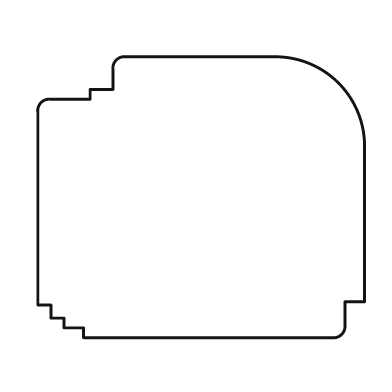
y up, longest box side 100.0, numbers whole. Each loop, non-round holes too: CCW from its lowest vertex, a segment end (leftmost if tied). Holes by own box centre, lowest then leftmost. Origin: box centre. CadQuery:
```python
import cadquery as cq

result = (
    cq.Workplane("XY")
    .moveTo(-36.0, -43.0)
    .lineTo(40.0, -43.0)
    .threePointArc((43.0, -42.0), (44.0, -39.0))
    .lineTo(44.0, -32.0)
    .lineTo(50.0, -32.0)
    .lineTo(50.0, 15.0)
    .threePointArc((42.0, 35.0), (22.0, 43.0))
    .lineTo(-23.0, 43.0)
    .threePointArc((-26.0, 42.0), (-27.0, 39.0))
    .lineTo(-27.0, 33.0)
    .lineTo(-34.0, 33.0)
    .lineTo(-34.0, 30.0)
    .lineTo(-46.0, 30.0)
    .threePointArc((-49.0, 29.0), (-50.0, 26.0))
    .lineTo(-50.0, -33.0)
    .lineTo(-46.0, -33.0)
    .lineTo(-46.0, -37.0)
    .lineTo(-42.0, -37.0)
    .lineTo(-42.0, -40.0)
    .lineTo(-36.0, -40.0)
    .close()
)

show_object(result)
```